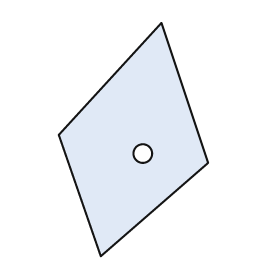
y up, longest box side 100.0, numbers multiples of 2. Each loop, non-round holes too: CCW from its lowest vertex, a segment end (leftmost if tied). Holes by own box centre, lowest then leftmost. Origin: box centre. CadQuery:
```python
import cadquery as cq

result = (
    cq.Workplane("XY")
    .moveTo(-14.0, -50.0)
    .lineTo(32.0, -10.0)
    .lineTo(12.0, 50.0)
    .lineTo(-32.0, 2.0)
    .close()
    .moveTo(4.0, -6.0)
    .circle(4.0)
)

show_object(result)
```